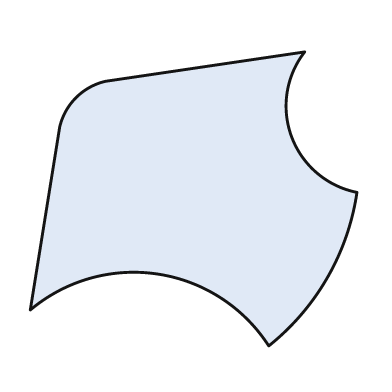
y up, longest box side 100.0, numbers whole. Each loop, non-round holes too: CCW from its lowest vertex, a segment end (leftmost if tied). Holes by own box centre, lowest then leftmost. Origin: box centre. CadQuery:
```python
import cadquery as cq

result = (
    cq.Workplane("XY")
    .moveTo(23.0, -45.0)
    .threePointArc((41.0, -24.0), (50.0, 2.0))
    .threePointArc((30.0, 19.0), (34.0, 45.0))
    .lineTo(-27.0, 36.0)
    .threePointArc((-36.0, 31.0), (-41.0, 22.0))
    .lineTo(-50.0, -34.0)
    .threePointArc((-11.0, -23.0), (23.0, -45.0))
    .close()
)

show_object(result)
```